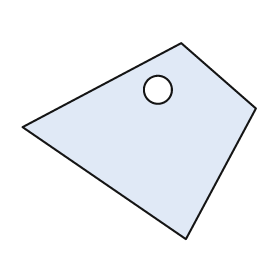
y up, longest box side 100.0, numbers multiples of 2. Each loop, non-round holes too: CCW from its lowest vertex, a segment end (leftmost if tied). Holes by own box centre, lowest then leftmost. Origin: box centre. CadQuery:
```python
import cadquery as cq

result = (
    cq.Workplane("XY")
    .moveTo(20.0, -42.0)
    .lineTo(50.0, 14.0)
    .lineTo(18.0, 42.0)
    .lineTo(-50.0, 6.0)
    .close()
    .moveTo(8.0, 22.0)
    .circle(6.0)
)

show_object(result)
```